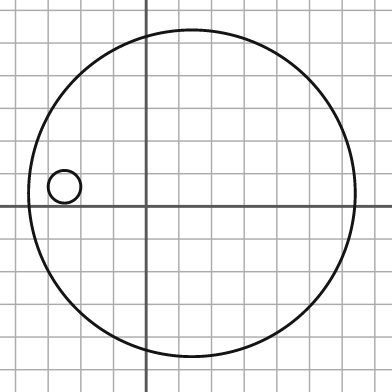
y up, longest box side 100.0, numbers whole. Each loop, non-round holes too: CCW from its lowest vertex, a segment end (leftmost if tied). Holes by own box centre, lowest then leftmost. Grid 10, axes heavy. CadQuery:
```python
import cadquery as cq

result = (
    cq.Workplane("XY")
    .moveTo(14.0, 4.0)
    .circle(50.0)
    .moveTo(-25.0, 6.0)
    .circle(5.0)
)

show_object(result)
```